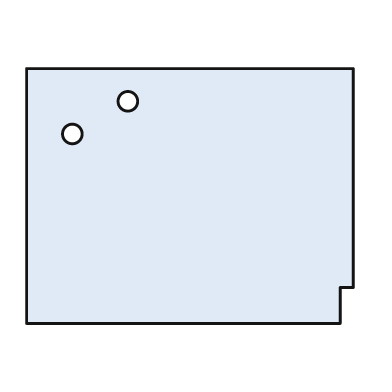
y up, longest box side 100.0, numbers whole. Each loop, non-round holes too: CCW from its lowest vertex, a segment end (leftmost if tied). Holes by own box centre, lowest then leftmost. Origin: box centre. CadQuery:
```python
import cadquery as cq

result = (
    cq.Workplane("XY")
    .moveTo(-50.0, -39.0)
    .lineTo(46.0, -39.0)
    .lineTo(46.0, -28.0)
    .lineTo(50.0, -28.0)
    .lineTo(50.0, 39.0)
    .lineTo(-50.0, 39.0)
    .close()
    .moveTo(-36.0, 19.0)
    .circle(3.0)
    .moveTo(-19.0, 29.0)
    .circle(3.0)
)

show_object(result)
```